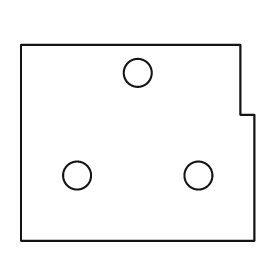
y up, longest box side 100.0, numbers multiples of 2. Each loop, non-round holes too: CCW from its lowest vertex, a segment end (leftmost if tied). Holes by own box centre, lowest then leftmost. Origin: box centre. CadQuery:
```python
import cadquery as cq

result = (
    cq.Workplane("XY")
    .moveTo(-50.0, -42.0)
    .lineTo(50.0, -42.0)
    .lineTo(50.0, 12.0)
    .lineTo(44.0, 12.0)
    .lineTo(44.0, 42.0)
    .lineTo(-50.0, 42.0)
    .close()
    .moveTo(-26.0, -14.0)
    .circle(6.0)
    .moveTo(26.0, -14.0)
    .circle(6.0)
    .moveTo(0.0, 30.0)
    .circle(6.0)
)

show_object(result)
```